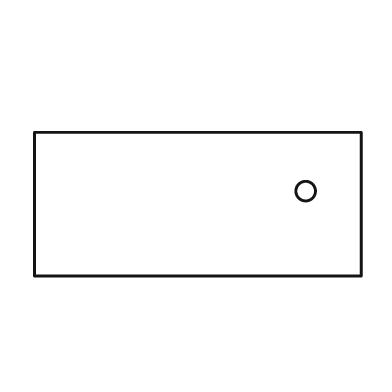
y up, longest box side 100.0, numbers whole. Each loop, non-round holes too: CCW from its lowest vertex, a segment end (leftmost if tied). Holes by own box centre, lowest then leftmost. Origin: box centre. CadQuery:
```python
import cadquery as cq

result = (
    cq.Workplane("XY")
    .moveTo(-50.0, -22.0)
    .lineTo(50.0, -22.0)
    .lineTo(50.0, 22.0)
    .lineTo(-50.0, 22.0)
    .close()
    .moveTo(33.0, 4.0)
    .circle(3.0)
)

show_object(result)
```